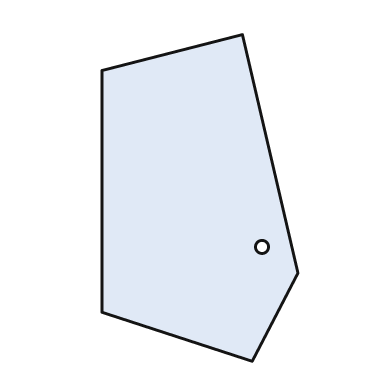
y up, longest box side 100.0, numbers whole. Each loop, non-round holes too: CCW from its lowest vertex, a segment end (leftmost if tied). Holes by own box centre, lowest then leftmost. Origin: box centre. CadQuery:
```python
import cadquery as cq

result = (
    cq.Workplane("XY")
    .moveTo(16.0, -50.0)
    .lineTo(30.0, -23.0)
    .lineTo(13.0, 50.0)
    .lineTo(-30.0, 39.0)
    .lineTo(-30.0, -35.0)
    .close()
    .moveTo(19.0, -15.0)
    .circle(2.0)
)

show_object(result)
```